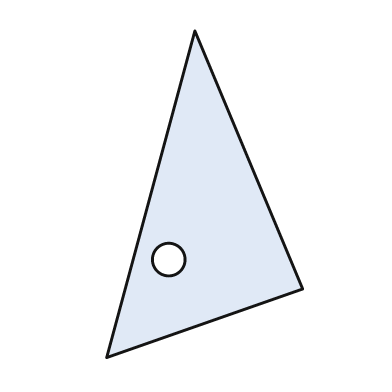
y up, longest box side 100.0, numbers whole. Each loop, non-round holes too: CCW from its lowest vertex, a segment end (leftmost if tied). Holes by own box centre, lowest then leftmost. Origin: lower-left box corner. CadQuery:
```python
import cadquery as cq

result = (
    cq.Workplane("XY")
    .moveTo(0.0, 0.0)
    .lineTo(60.0, 21.0)
    .lineTo(27.0, 100.0)
    .close()
    .moveTo(19.0, 30.0)
    .circle(5.0)
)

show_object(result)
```